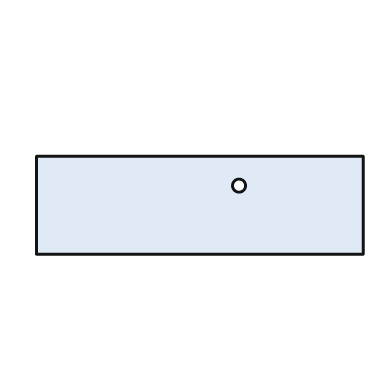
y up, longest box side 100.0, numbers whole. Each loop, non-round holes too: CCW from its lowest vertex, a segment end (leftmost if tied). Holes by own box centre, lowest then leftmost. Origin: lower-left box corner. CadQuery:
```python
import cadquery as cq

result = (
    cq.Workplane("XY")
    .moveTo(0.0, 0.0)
    .lineTo(100.0, 0.0)
    .lineTo(100.0, 30.0)
    .lineTo(0.0, 30.0)
    .close()
    .moveTo(62.0, 21.0)
    .circle(2.0)
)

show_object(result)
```